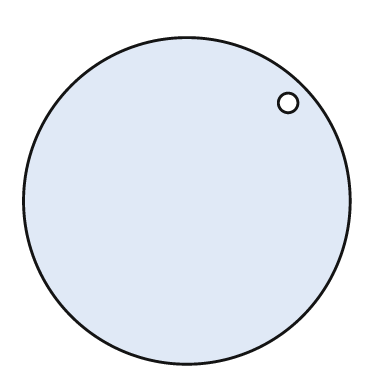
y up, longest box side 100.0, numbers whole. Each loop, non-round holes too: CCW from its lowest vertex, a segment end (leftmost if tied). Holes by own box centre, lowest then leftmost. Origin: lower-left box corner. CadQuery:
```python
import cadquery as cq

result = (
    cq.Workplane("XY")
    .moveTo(50.0, 50.0)
    .circle(50.0)
    .moveTo(81.0, 80.0)
    .circle(3.0)
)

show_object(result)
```